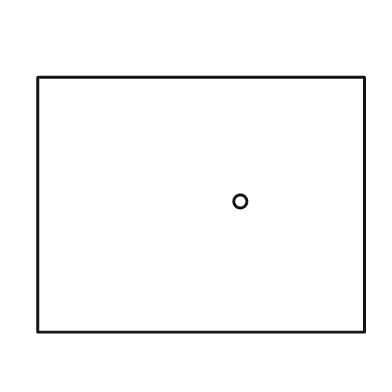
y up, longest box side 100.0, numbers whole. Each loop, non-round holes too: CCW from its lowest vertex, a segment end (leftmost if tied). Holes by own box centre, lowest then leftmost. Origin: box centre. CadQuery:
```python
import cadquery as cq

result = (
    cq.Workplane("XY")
    .moveTo(-50.0, -39.0)
    .lineTo(50.0, -39.0)
    .lineTo(50.0, 39.0)
    .lineTo(-50.0, 39.0)
    .close()
    .moveTo(12.0, 1.0)
    .circle(2.0)
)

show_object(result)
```